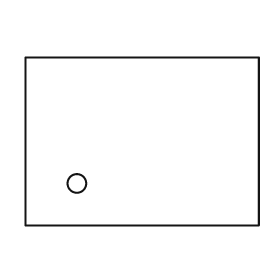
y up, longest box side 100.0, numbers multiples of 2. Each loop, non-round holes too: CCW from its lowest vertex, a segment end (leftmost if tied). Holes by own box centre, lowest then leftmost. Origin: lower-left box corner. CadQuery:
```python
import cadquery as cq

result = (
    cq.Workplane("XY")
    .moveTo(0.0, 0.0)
    .lineTo(100.0, 0.0)
    .lineTo(100.0, 72.0)
    .lineTo(0.0, 72.0)
    .close()
    .moveTo(22.0, 18.0)
    .circle(4.0)
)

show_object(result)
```